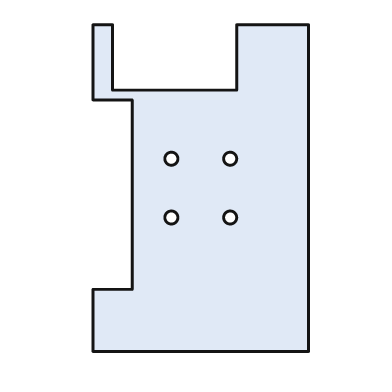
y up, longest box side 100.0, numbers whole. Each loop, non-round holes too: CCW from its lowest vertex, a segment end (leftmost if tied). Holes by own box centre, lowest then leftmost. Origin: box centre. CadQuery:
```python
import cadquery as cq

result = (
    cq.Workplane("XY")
    .moveTo(-33.0, -50.0)
    .lineTo(33.0, -50.0)
    .lineTo(33.0, 50.0)
    .lineTo(11.0, 50.0)
    .lineTo(11.0, 30.0)
    .lineTo(-27.0, 30.0)
    .lineTo(-27.0, 50.0)
    .lineTo(-33.0, 50.0)
    .lineTo(-33.0, 27.0)
    .lineTo(-21.0, 27.0)
    .lineTo(-21.0, -31.0)
    .lineTo(-33.0, -31.0)
    .close()
    .moveTo(-9.0, -9.0)
    .circle(2.0)
    .moveTo(9.0, -9.0)
    .circle(2.0)
    .moveTo(-9.0, 9.0)
    .circle(2.0)
    .moveTo(9.0, 9.0)
    .circle(2.0)
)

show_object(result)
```